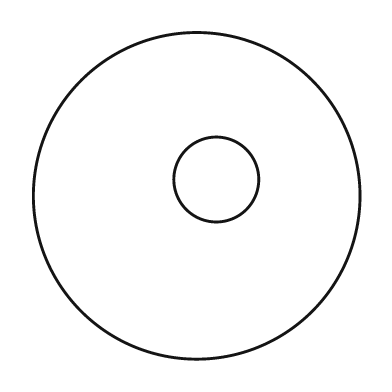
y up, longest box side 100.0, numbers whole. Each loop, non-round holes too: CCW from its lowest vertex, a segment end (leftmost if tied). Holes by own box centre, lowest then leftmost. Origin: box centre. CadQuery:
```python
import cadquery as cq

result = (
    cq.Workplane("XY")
    .moveTo(0.0, 0.0)
    .circle(50.0)
    .moveTo(6.0, 5.0)
    .circle(13.0)
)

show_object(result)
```